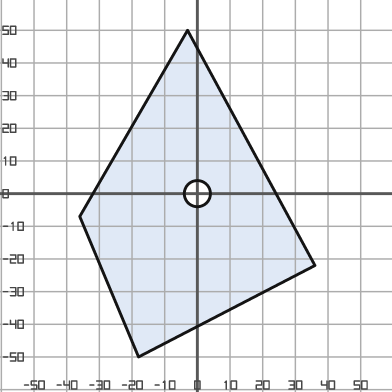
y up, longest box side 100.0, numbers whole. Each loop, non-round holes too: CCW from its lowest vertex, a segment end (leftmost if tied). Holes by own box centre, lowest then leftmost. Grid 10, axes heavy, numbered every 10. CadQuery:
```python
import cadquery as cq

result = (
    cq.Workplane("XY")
    .moveTo(-18.0, -50.0)
    .lineTo(36.0, -22.0)
    .lineTo(-3.0, 50.0)
    .lineTo(-36.0, -7.0)
    .close()
    .moveTo(0.0, 0.0)
    .circle(4.0)
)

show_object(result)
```